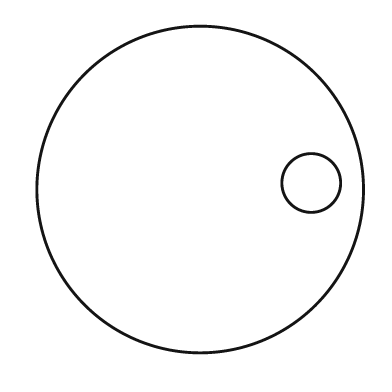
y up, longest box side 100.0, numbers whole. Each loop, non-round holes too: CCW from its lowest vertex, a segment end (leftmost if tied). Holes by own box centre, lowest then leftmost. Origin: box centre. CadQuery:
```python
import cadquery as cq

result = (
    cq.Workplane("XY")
    .moveTo(0.0, 0.0)
    .circle(50.0)
    .moveTo(34.0, 2.0)
    .circle(9.0)
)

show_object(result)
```